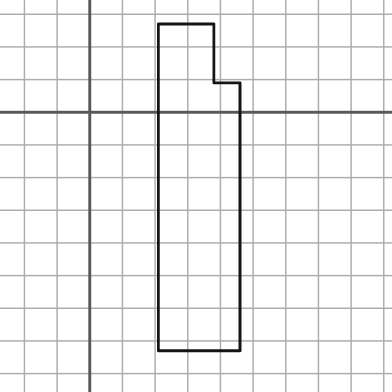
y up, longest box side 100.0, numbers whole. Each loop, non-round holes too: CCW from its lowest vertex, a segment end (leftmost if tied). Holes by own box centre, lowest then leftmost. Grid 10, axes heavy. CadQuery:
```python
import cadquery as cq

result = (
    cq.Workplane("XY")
    .moveTo(21.0, -73.0)
    .lineTo(46.0, -73.0)
    .lineTo(46.0, 9.0)
    .lineTo(38.0, 9.0)
    .lineTo(38.0, 27.0)
    .lineTo(21.0, 27.0)
    .close()
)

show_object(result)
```